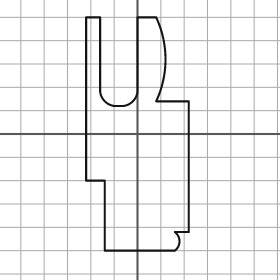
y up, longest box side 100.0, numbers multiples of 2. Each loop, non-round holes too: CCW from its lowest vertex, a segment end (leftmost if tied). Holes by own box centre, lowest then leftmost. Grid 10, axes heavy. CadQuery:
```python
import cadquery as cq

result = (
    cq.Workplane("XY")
    .moveTo(-14.0, -50.0)
    .lineTo(16.0, -50.0)
    .threePointArc((18.0, -46.0), (16.0, -42.0))
    .lineTo(22.0, -42.0)
    .lineTo(22.0, 14.0)
    .lineTo(8.0, 14.0)
    .threePointArc((12.0, 32.0), (8.0, 50.0))
    .lineTo(0.0, 50.0)
    .lineTo(0.0, 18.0)
    .threePointArc((-2.0, 14.0), (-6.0, 12.0))
    .lineTo(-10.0, 12.0)
    .threePointArc((-14.0, 14.0), (-16.0, 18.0))
    .lineTo(-16.0, 50.0)
    .lineTo(-22.0, 50.0)
    .lineTo(-22.0, -20.0)
    .lineTo(-14.0, -20.0)
    .close()
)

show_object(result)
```